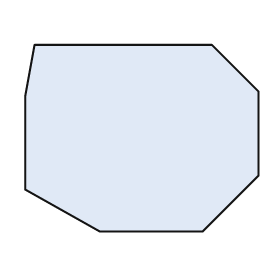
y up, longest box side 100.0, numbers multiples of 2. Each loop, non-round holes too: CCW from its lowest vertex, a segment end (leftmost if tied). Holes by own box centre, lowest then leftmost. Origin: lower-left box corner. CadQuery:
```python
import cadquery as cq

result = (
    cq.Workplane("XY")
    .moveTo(32.0, 0.0)
    .lineTo(76.0, 0.0)
    .lineTo(100.0, 24.0)
    .lineTo(100.0, 60.0)
    .lineTo(80.0, 80.0)
    .lineTo(4.0, 80.0)
    .lineTo(0.0, 58.0)
    .lineTo(0.0, 18.0)
    .close()
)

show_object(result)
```